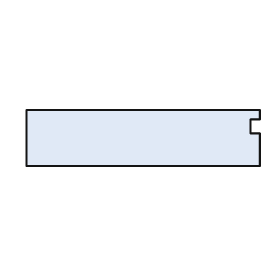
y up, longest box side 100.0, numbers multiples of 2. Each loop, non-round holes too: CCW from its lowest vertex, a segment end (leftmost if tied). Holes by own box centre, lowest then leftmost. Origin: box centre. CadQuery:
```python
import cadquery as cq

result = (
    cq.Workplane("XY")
    .moveTo(-50.0, -12.0)
    .lineTo(50.0, -12.0)
    .lineTo(50.0, 2.0)
    .lineTo(46.0, 2.0)
    .lineTo(46.0, 8.0)
    .lineTo(50.0, 8.0)
    .lineTo(50.0, 12.0)
    .lineTo(-50.0, 12.0)
    .close()
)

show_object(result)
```